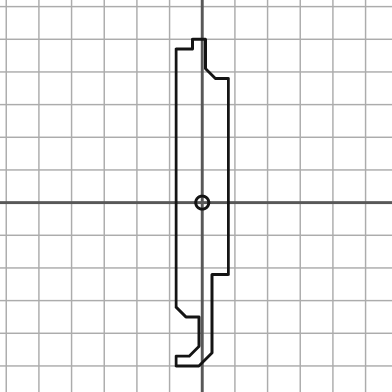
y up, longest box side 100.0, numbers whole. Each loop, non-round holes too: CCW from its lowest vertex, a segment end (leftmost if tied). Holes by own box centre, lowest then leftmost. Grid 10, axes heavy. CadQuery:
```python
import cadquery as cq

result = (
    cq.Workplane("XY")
    .moveTo(-8.0, -50.0)
    .lineTo(-1.0, -50.0)
    .lineTo(3.0, -46.0)
    .lineTo(3.0, -22.0)
    .lineTo(8.0, -22.0)
    .lineTo(8.0, 38.0)
    .lineTo(4.0, 38.0)
    .lineTo(1.0, 41.0)
    .lineTo(1.0, 50.0)
    .lineTo(-3.0, 50.0)
    .lineTo(-3.0, 47.0)
    .lineTo(-8.0, 47.0)
    .lineTo(-8.0, -32.0)
    .lineTo(-5.0, -35.0)
    .lineTo(-1.0, -35.0)
    .lineTo(-1.0, -44.0)
    .lineTo(-4.0, -47.0)
    .lineTo(-8.0, -47.0)
    .close()
    .moveTo(0.0, 0.0)
    .circle(2.0)
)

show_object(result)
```